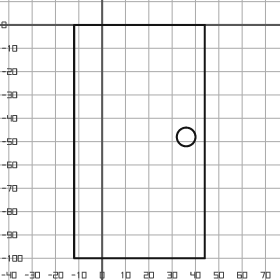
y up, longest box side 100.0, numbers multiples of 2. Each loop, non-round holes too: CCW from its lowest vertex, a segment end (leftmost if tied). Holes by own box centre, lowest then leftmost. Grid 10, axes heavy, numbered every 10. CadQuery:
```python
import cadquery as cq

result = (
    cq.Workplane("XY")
    .moveTo(-12.0, -100.0)
    .lineTo(44.0, -100.0)
    .lineTo(44.0, 0.0)
    .lineTo(-12.0, 0.0)
    .close()
    .moveTo(36.0, -48.0)
    .circle(4.0)
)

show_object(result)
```